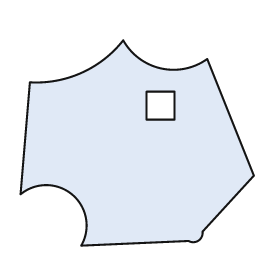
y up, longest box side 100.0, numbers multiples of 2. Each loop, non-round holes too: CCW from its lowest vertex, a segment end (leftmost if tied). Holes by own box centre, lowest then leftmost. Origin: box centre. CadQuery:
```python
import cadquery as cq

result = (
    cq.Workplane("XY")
    .moveTo(-24.0, -44.0)
    .lineTo(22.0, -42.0)
    .threePointArc((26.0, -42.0), (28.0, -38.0))
    .lineTo(50.0, -14.0)
    .lineTo(30.0, 36.0)
    .threePointArc((10.0, 32.0), (-6.0, 44.0))
    .threePointArc((-24.0, 30.0), (-46.0, 26.0))
    .lineTo(-50.0, -22.0)
    .threePointArc((-28.0, -22.0), (-24.0, -44.0))
    .close()
    .moveTo(4.0, 10.0)
    .lineTo(16.0, 10.0)
    .lineTo(16.0, 22.0)
    .lineTo(4.0, 22.0)
    .close()
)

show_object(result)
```